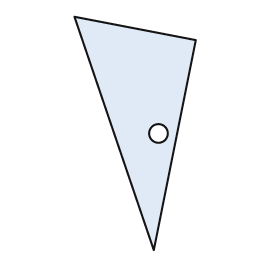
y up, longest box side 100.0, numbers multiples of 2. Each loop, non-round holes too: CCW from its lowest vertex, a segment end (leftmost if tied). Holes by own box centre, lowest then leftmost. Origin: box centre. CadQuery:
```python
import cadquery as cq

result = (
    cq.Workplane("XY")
    .moveTo(8.0, -50.0)
    .lineTo(26.0, 40.0)
    .lineTo(-26.0, 50.0)
    .close()
    .moveTo(10.0, 0.0)
    .circle(4.0)
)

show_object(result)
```